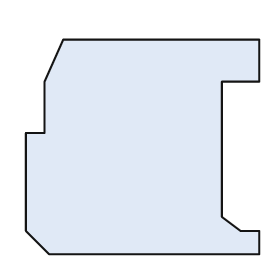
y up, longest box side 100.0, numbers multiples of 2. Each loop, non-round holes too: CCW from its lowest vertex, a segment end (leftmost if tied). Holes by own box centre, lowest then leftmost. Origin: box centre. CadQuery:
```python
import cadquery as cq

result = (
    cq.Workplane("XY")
    .moveTo(-40.0, -46.0)
    .lineTo(50.0, -46.0)
    .lineTo(50.0, -36.0)
    .lineTo(42.0, -36.0)
    .lineTo(34.0, -30.0)
    .lineTo(34.0, 28.0)
    .lineTo(50.0, 28.0)
    .lineTo(50.0, 46.0)
    .lineTo(-34.0, 46.0)
    .lineTo(-42.0, 28.0)
    .lineTo(-42.0, 6.0)
    .lineTo(-50.0, 6.0)
    .lineTo(-50.0, -36.0)
    .close()
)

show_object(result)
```